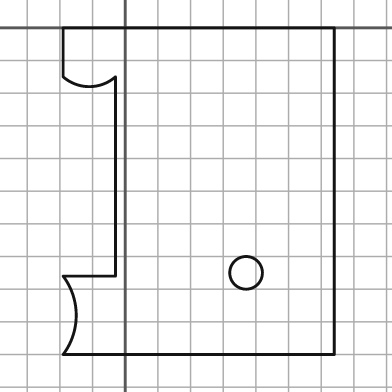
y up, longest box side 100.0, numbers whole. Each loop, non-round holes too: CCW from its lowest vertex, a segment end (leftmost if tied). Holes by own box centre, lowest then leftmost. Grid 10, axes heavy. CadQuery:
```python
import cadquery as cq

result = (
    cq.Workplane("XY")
    .moveTo(-19.0, -100.0)
    .lineTo(64.0, -100.0)
    .lineTo(64.0, 0.0)
    .lineTo(-19.0, 0.0)
    .lineTo(-19.0, -15.0)
    .threePointArc((-11.0, -18.0), (-3.0, -15.0))
    .lineTo(-3.0, -76.0)
    .lineTo(-19.0, -76.0)
    .threePointArc((-15.0, -88.0), (-19.0, -100.0))
    .close()
    .moveTo(37.0, -75.0)
    .circle(5.0)
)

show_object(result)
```